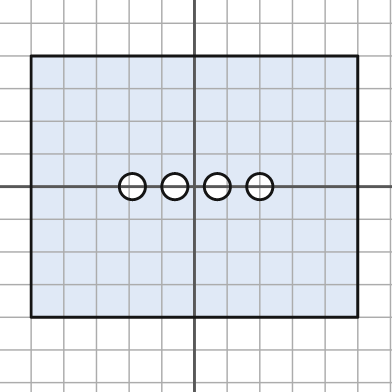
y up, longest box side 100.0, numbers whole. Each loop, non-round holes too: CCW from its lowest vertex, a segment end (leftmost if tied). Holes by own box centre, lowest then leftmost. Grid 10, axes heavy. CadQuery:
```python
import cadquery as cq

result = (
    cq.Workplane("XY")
    .moveTo(-50.0, -40.0)
    .lineTo(50.0, -40.0)
    .lineTo(50.0, 40.0)
    .lineTo(-50.0, 40.0)
    .close()
    .moveTo(-19.0, 0.0)
    .circle(4.0)
    .moveTo(-6.0, 0.0)
    .circle(4.0)
    .moveTo(7.0, 0.0)
    .circle(4.0)
    .moveTo(20.0, 0.0)
    .circle(4.0)
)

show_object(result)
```